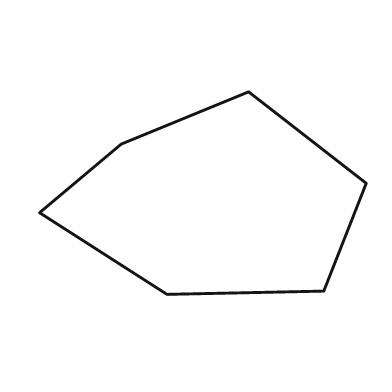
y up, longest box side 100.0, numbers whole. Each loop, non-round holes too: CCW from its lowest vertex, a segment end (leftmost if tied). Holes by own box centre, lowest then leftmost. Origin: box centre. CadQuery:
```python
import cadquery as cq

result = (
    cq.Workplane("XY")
    .moveTo(-11.0, -31.0)
    .lineTo(37.0, -30.0)
    .lineTo(50.0, 3.0)
    .lineTo(14.0, 31.0)
    .lineTo(-25.0, 15.0)
    .lineTo(-50.0, -6.0)
    .close()
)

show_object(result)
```